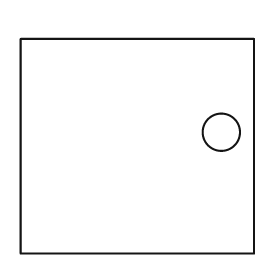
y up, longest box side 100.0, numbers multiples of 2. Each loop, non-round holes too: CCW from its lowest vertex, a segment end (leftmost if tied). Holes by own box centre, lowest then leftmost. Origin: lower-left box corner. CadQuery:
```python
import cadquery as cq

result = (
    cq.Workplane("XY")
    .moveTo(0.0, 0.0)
    .lineTo(100.0, 0.0)
    .lineTo(100.0, 92.0)
    .lineTo(0.0, 92.0)
    .close()
    .moveTo(86.0, 52.0)
    .circle(8.0)
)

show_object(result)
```